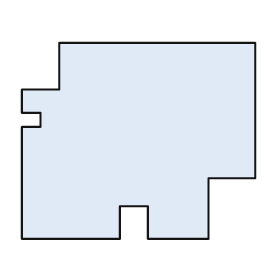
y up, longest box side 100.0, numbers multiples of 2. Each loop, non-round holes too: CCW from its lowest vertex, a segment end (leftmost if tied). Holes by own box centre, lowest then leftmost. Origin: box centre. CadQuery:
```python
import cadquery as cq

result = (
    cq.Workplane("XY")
    .moveTo(-50.0, -42.0)
    .lineTo(-8.0, -42.0)
    .lineTo(-8.0, -28.0)
    .lineTo(4.0, -28.0)
    .lineTo(4.0, -42.0)
    .lineTo(30.0, -42.0)
    .lineTo(30.0, -16.0)
    .lineTo(50.0, -16.0)
    .lineTo(50.0, 42.0)
    .lineTo(-34.0, 42.0)
    .lineTo(-34.0, 22.0)
    .lineTo(-50.0, 22.0)
    .lineTo(-50.0, 12.0)
    .lineTo(-42.0, 12.0)
    .lineTo(-42.0, 6.0)
    .lineTo(-50.0, 6.0)
    .close()
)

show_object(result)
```